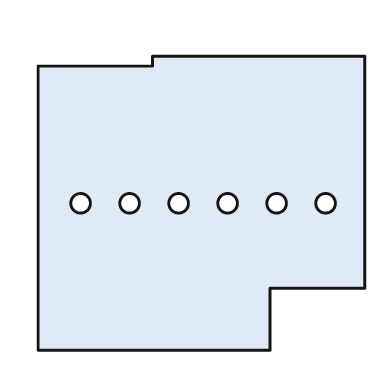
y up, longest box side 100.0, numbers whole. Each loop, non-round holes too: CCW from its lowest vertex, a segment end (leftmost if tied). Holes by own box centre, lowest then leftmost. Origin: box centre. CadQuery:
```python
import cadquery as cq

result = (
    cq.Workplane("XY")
    .moveTo(-50.0, -45.0)
    .lineTo(21.0, -45.0)
    .lineTo(21.0, -26.0)
    .lineTo(50.0, -26.0)
    .lineTo(50.0, 45.0)
    .lineTo(-15.0, 45.0)
    .lineTo(-15.0, 42.0)
    .lineTo(-50.0, 42.0)
    .close()
    .moveTo(-37.0, 0.0)
    .circle(3.0)
    .moveTo(-22.0, 0.0)
    .circle(3.0)
    .moveTo(-7.0, 0.0)
    .circle(3.0)
    .moveTo(8.0, 0.0)
    .circle(3.0)
    .moveTo(23.0, 0.0)
    .circle(3.0)
    .moveTo(38.0, 0.0)
    .circle(3.0)
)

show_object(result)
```